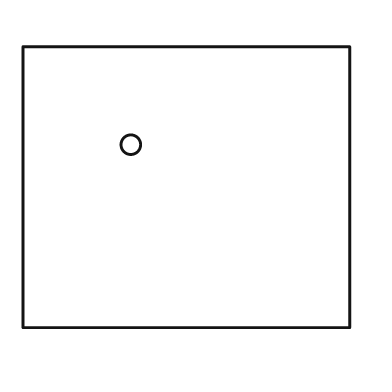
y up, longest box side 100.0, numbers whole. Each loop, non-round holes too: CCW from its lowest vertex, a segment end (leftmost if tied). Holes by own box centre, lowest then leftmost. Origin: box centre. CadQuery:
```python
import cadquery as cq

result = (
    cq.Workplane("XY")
    .moveTo(-50.0, -43.0)
    .lineTo(50.0, -43.0)
    .lineTo(50.0, 43.0)
    .lineTo(-50.0, 43.0)
    .close()
    .moveTo(-17.0, 13.0)
    .circle(3.0)
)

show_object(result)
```